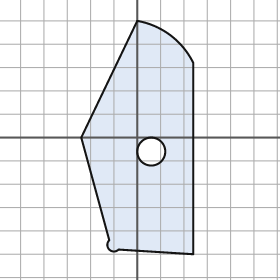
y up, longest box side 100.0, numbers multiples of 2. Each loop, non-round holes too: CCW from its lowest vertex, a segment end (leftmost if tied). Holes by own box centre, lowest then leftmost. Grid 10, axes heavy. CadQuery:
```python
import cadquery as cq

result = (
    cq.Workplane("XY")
    .moveTo(24.0, -50.0)
    .lineTo(24.0, 32.0)
    .threePointArc((14.0, 44.0), (0.0, 50.0))
    .lineTo(-24.0, 0.0)
    .lineTo(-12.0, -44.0)
    .threePointArc((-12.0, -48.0), (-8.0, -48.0))
    .close()
    .moveTo(6.0, -6.0)
    .circle(6.0)
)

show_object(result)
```